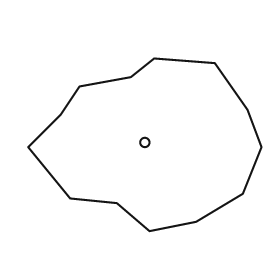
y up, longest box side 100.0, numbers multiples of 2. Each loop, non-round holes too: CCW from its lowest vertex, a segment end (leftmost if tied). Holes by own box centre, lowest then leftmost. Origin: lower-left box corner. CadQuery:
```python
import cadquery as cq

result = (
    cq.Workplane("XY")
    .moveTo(52.0, 0.0)
    .lineTo(72.0, 4.0)
    .lineTo(92.0, 16.0)
    .lineTo(100.0, 36.0)
    .lineTo(94.0, 52.0)
    .lineTo(80.0, 72.0)
    .lineTo(54.0, 74.0)
    .lineTo(44.0, 66.0)
    .lineTo(22.0, 62.0)
    .lineTo(14.0, 50.0)
    .lineTo(0.0, 36.0)
    .lineTo(18.0, 14.0)
    .lineTo(38.0, 12.0)
    .close()
    .moveTo(50.0, 38.0)
    .circle(2.0)
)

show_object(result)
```